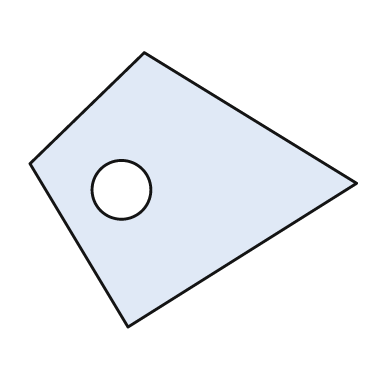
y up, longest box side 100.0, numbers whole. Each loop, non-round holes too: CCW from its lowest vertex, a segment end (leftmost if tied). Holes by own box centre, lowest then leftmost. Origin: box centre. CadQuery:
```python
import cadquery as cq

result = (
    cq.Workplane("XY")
    .moveTo(-20.0, -42.0)
    .lineTo(50.0, 2.0)
    .lineTo(-15.0, 42.0)
    .lineTo(-50.0, 8.0)
    .close()
    .moveTo(-22.0, 0.0)
    .circle(9.0)
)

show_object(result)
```